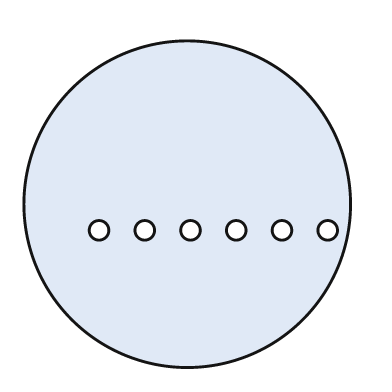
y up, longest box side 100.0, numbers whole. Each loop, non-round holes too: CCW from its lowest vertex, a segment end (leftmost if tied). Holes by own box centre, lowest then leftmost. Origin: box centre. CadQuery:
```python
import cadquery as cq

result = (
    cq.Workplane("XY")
    .moveTo(0.0, 0.0)
    .circle(50.0)
    .moveTo(-27.0, -8.0)
    .circle(3.0)
    .moveTo(-13.0, -8.0)
    .circle(3.0)
    .moveTo(1.0, -8.0)
    .circle(3.0)
    .moveTo(15.0, -8.0)
    .circle(3.0)
    .moveTo(29.0, -8.0)
    .circle(3.0)
    .moveTo(43.0, -8.0)
    .circle(3.0)
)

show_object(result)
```